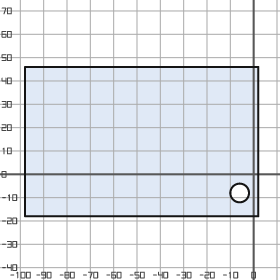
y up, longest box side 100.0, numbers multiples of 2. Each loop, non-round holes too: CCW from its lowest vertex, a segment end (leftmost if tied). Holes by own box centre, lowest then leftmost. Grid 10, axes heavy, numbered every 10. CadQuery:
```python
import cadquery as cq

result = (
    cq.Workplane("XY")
    .moveTo(-98.0, -18.0)
    .lineTo(2.0, -18.0)
    .lineTo(2.0, 46.0)
    .lineTo(-98.0, 46.0)
    .close()
    .moveTo(-6.0, -8.0)
    .circle(4.0)
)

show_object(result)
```